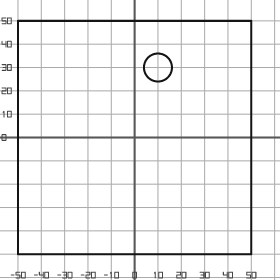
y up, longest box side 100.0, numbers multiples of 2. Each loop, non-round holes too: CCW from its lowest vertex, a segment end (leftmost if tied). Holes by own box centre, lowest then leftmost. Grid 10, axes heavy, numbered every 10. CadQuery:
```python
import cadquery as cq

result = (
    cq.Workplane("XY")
    .moveTo(-50.0, -50.0)
    .lineTo(50.0, -50.0)
    .lineTo(50.0, 50.0)
    .lineTo(-50.0, 50.0)
    .close()
    .moveTo(10.0, 30.0)
    .circle(6.0)
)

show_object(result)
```